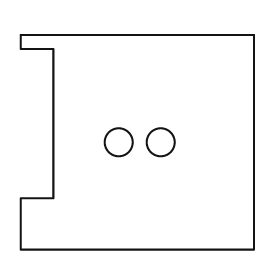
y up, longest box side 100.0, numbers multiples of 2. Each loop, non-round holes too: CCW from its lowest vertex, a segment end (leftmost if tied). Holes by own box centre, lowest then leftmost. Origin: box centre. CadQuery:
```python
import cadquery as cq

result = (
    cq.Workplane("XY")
    .moveTo(-50.0, -46.0)
    .lineTo(50.0, -46.0)
    .lineTo(50.0, 46.0)
    .lineTo(-50.0, 46.0)
    .lineTo(-50.0, 40.0)
    .lineTo(-36.0, 40.0)
    .lineTo(-36.0, -24.0)
    .lineTo(-50.0, -24.0)
    .close()
    .moveTo(-8.0, 0.0)
    .circle(6.0)
    .moveTo(10.0, 0.0)
    .circle(6.0)
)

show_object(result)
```